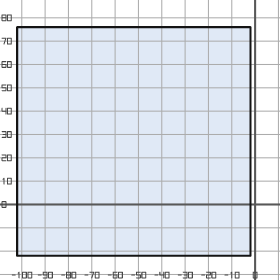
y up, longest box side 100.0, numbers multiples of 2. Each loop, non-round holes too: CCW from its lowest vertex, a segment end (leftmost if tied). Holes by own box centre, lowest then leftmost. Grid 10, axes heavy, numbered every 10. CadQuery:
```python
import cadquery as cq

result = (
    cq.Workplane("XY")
    .moveTo(-102.0, -22.0)
    .lineTo(-2.0, -22.0)
    .lineTo(-2.0, 76.0)
    .lineTo(-102.0, 76.0)
    .close()
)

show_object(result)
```